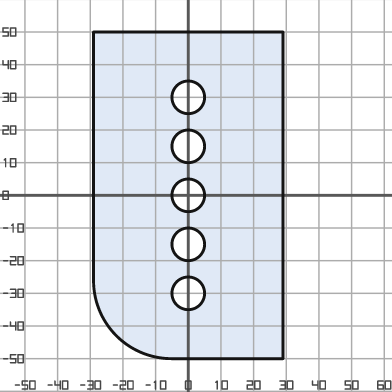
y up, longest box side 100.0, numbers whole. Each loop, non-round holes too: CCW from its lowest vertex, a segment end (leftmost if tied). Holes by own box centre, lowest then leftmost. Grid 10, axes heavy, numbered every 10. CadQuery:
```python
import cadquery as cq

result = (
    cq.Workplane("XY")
    .moveTo(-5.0, -50.0)
    .lineTo(29.0, -50.0)
    .lineTo(29.0, 50.0)
    .lineTo(-29.0, 50.0)
    .lineTo(-29.0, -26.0)
    .threePointArc((-22.0, -43.0), (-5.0, -50.0))
    .close()
    .moveTo(0.0, -30.0)
    .circle(5.0)
    .moveTo(0.0, -15.0)
    .circle(5.0)
    .moveTo(0.0, 0.0)
    .circle(5.0)
    .moveTo(0.0, 15.0)
    .circle(5.0)
    .moveTo(0.0, 30.0)
    .circle(5.0)
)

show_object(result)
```